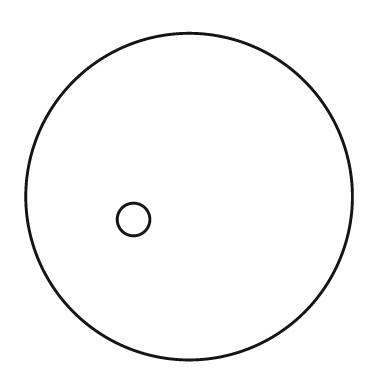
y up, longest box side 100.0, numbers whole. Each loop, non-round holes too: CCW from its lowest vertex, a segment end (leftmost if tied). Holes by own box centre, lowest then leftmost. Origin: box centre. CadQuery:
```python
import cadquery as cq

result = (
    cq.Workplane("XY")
    .moveTo(0.0, 0.0)
    .circle(50.0)
    .moveTo(-17.0, -7.0)
    .circle(5.0)
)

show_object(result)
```